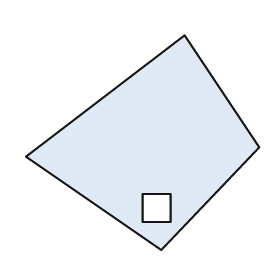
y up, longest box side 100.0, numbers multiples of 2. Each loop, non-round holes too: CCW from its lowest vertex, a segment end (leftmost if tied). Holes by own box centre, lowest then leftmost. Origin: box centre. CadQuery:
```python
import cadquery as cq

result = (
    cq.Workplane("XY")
    .moveTo(8.0, -46.0)
    .lineTo(50.0, -2.0)
    .lineTo(18.0, 46.0)
    .lineTo(-50.0, -6.0)
    .close()
    .moveTo(0.0, -34.0)
    .lineTo(12.0, -34.0)
    .lineTo(12.0, -22.0)
    .lineTo(0.0, -22.0)
    .close()
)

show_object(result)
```